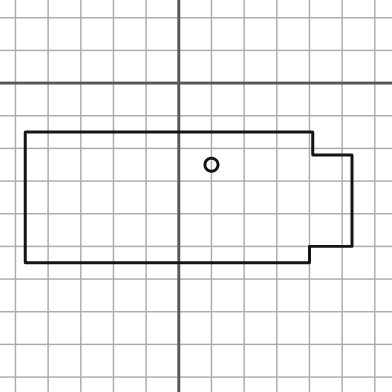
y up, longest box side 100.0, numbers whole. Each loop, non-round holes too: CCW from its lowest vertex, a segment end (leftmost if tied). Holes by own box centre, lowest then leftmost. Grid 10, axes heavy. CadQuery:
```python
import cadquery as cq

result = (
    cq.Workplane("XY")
    .moveTo(-47.0, -55.0)
    .lineTo(40.0, -55.0)
    .lineTo(40.0, -50.0)
    .lineTo(53.0, -50.0)
    .lineTo(53.0, -22.0)
    .lineTo(41.0, -22.0)
    .lineTo(41.0, -15.0)
    .lineTo(-47.0, -15.0)
    .close()
    .moveTo(10.0, -25.0)
    .circle(2.0)
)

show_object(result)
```